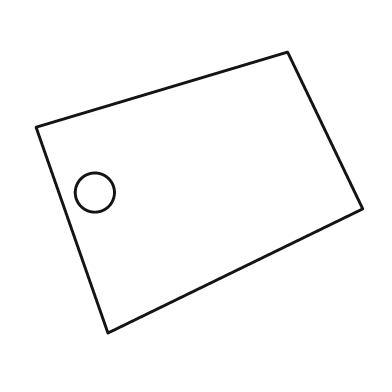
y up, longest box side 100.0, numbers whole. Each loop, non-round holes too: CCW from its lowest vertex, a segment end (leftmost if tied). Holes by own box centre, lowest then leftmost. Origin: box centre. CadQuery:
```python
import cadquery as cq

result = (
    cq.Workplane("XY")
    .moveTo(-28.0, -43.0)
    .lineTo(50.0, -5.0)
    .lineTo(27.0, 43.0)
    .lineTo(-50.0, 20.0)
    .close()
    .moveTo(-32.0, 0.0)
    .circle(6.0)
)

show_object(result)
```